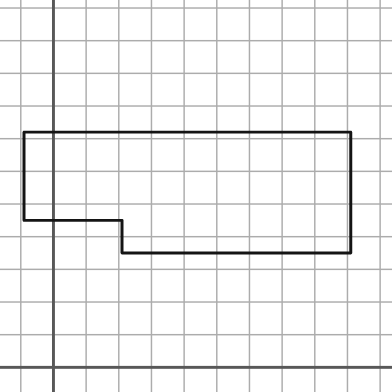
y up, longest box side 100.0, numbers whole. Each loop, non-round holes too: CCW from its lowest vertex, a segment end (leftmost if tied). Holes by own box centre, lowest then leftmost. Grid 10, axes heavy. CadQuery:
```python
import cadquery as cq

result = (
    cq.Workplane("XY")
    .moveTo(21.0, 35.0)
    .lineTo(91.0, 35.0)
    .lineTo(91.0, 72.0)
    .lineTo(-9.0, 72.0)
    .lineTo(-9.0, 45.0)
    .lineTo(21.0, 45.0)
    .close()
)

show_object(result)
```